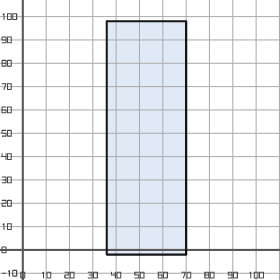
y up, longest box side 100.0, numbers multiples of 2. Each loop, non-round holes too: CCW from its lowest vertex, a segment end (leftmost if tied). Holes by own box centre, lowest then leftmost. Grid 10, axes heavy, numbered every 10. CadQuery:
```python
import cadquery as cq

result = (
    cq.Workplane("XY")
    .moveTo(36.0, -2.0)
    .lineTo(70.0, -2.0)
    .lineTo(70.0, 98.0)
    .lineTo(36.0, 98.0)
    .close()
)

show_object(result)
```